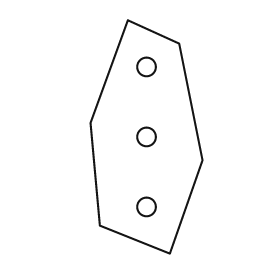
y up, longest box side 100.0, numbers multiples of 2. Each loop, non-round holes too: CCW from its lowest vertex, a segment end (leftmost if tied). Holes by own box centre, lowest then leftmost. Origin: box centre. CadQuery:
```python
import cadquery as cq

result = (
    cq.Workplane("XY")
    .moveTo(10.0, -50.0)
    .lineTo(24.0, -10.0)
    .lineTo(14.0, 40.0)
    .lineTo(-8.0, 50.0)
    .lineTo(-24.0, 6.0)
    .lineTo(-20.0, -38.0)
    .close()
    .moveTo(0.0, -30.0)
    .circle(4.0)
    .moveTo(0.0, 0.0)
    .circle(4.0)
    .moveTo(0.0, 30.0)
    .circle(4.0)
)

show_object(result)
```